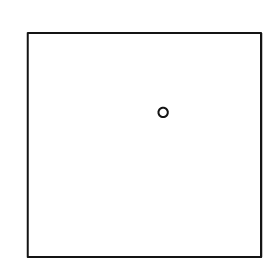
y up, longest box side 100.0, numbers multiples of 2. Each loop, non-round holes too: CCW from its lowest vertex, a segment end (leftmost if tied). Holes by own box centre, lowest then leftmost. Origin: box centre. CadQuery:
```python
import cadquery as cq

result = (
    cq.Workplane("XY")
    .moveTo(-50.0, -48.0)
    .lineTo(50.0, -48.0)
    .lineTo(50.0, 48.0)
    .lineTo(-50.0, 48.0)
    .close()
    .moveTo(8.0, 14.0)
    .circle(2.0)
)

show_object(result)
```